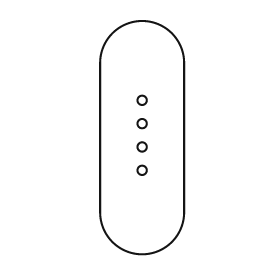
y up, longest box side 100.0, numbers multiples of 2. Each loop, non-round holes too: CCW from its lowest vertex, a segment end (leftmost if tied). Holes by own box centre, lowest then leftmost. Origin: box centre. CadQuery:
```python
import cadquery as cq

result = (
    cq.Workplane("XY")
    .moveTo(-18.0, -32.0)
    .threePointArc((0.0, -50.0), (18.0, -32.0))
    .lineTo(18.0, 32.0)
    .threePointArc((0.0, 50.0), (-18.0, 32.0))
    .close()
    .moveTo(0.0, -14.0)
    .circle(2.0)
    .moveTo(0.0, -4.0)
    .circle(2.0)
    .moveTo(0.0, 6.0)
    .circle(2.0)
    .moveTo(0.0, 16.0)
    .circle(2.0)
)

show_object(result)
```